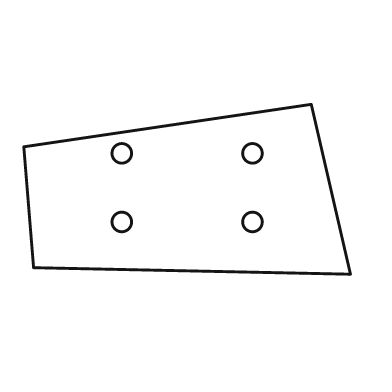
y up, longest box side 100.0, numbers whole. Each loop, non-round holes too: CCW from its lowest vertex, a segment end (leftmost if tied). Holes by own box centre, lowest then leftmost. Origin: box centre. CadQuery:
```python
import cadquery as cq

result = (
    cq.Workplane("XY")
    .moveTo(50.0, -26.0)
    .lineTo(38.0, 26.0)
    .lineTo(-50.0, 13.0)
    .lineTo(-47.0, -24.0)
    .close()
    .moveTo(-20.0, -10.0)
    .circle(3.0)
    .moveTo(20.0, -10.0)
    .circle(3.0)
    .moveTo(-20.0, 11.0)
    .circle(3.0)
    .moveTo(20.0, 11.0)
    .circle(3.0)
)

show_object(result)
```